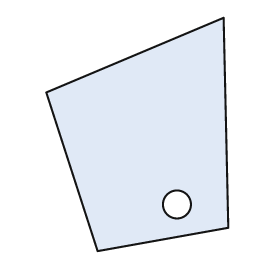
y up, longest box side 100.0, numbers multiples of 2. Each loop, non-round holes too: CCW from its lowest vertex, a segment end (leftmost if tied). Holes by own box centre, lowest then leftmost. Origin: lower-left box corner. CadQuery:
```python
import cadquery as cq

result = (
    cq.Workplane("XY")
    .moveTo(22.0, 0.0)
    .lineTo(78.0, 10.0)
    .lineTo(76.0, 100.0)
    .lineTo(0.0, 68.0)
    .close()
    .moveTo(56.0, 20.0)
    .circle(6.0)
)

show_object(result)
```